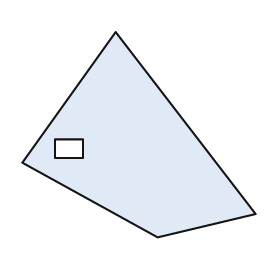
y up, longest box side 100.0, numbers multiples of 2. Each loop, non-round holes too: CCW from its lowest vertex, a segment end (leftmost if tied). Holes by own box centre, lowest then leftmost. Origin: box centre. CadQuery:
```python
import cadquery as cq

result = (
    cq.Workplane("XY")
    .moveTo(8.0, -44.0)
    .lineTo(50.0, -34.0)
    .lineTo(-10.0, 44.0)
    .lineTo(-50.0, -12.0)
    .close()
    .moveTo(-36.0, -10.0)
    .lineTo(-24.0, -10.0)
    .lineTo(-24.0, -2.0)
    .lineTo(-36.0, -2.0)
    .close()
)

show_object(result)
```